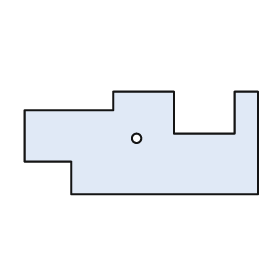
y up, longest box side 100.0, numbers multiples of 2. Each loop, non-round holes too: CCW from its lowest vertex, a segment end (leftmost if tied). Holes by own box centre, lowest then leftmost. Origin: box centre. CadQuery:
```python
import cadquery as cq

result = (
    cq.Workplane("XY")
    .moveTo(-30.0, -22.0)
    .lineTo(50.0, -22.0)
    .lineTo(50.0, 22.0)
    .lineTo(40.0, 22.0)
    .lineTo(40.0, 4.0)
    .lineTo(14.0, 4.0)
    .lineTo(14.0, 22.0)
    .lineTo(-12.0, 22.0)
    .lineTo(-12.0, 14.0)
    .lineTo(-50.0, 14.0)
    .lineTo(-50.0, -8.0)
    .lineTo(-30.0, -8.0)
    .close()
    .moveTo(-2.0, 2.0)
    .circle(2.0)
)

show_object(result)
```